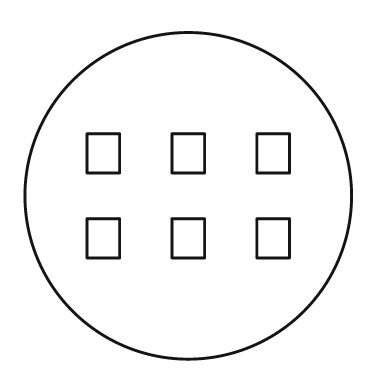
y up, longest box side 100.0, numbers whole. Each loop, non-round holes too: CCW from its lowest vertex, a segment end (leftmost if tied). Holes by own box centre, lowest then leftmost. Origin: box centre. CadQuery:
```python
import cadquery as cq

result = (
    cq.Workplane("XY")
    .moveTo(0.0, 0.0)
    .circle(50.0)
    .moveTo(-31.0, -19.0)
    .lineTo(-21.0, -19.0)
    .lineTo(-21.0, -7.0)
    .lineTo(-31.0, -7.0)
    .close()
    .moveTo(-5.0, -19.0)
    .lineTo(5.0, -19.0)
    .lineTo(5.0, -7.0)
    .lineTo(-5.0, -7.0)
    .close()
    .moveTo(21.0, -19.0)
    .lineTo(31.0, -19.0)
    .lineTo(31.0, -7.0)
    .lineTo(21.0, -7.0)
    .close()
    .moveTo(-31.0, 7.0)
    .lineTo(-21.0, 7.0)
    .lineTo(-21.0, 19.0)
    .lineTo(-31.0, 19.0)
    .close()
    .moveTo(-5.0, 7.0)
    .lineTo(5.0, 7.0)
    .lineTo(5.0, 19.0)
    .lineTo(-5.0, 19.0)
    .close()
    .moveTo(21.0, 7.0)
    .lineTo(31.0, 7.0)
    .lineTo(31.0, 19.0)
    .lineTo(21.0, 19.0)
    .close()
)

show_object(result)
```